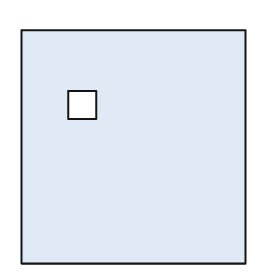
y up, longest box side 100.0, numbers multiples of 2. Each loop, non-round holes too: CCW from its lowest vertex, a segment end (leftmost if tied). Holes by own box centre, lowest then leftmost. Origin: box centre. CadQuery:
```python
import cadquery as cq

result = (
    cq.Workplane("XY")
    .moveTo(-48.0, -50.0)
    .lineTo(48.0, -50.0)
    .lineTo(48.0, 50.0)
    .lineTo(-48.0, 50.0)
    .close()
    .moveTo(-28.0, 12.0)
    .lineTo(-16.0, 12.0)
    .lineTo(-16.0, 24.0)
    .lineTo(-28.0, 24.0)
    .close()
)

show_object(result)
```